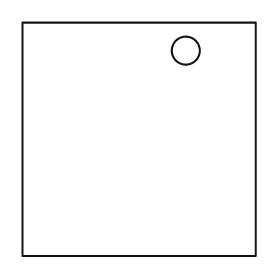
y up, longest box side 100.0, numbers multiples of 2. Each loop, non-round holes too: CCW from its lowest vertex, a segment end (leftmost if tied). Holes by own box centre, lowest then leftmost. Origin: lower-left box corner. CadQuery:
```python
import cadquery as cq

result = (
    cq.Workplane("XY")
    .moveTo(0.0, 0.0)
    .lineTo(100.0, 0.0)
    .lineTo(100.0, 100.0)
    .lineTo(0.0, 100.0)
    .close()
    .moveTo(70.0, 88.0)
    .circle(6.0)
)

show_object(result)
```